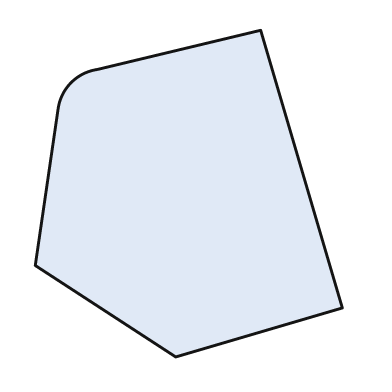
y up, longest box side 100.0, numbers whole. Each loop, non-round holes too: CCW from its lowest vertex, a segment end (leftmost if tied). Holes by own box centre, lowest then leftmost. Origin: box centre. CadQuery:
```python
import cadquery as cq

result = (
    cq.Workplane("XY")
    .moveTo(-4.0, -50.0)
    .lineTo(47.0, -35.0)
    .lineTo(22.0, 50.0)
    .lineTo(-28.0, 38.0)
    .threePointArc((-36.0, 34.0), (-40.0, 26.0))
    .lineTo(-47.0, -22.0)
    .close()
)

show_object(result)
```